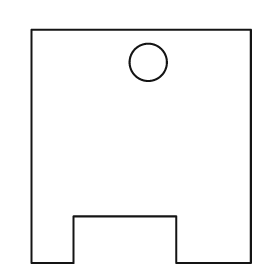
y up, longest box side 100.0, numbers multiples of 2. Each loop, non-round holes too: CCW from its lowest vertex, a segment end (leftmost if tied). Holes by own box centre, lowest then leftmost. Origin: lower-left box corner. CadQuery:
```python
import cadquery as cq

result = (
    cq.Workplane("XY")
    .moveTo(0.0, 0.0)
    .lineTo(18.0, 0.0)
    .lineTo(18.0, 20.0)
    .lineTo(62.0, 20.0)
    .lineTo(62.0, 0.0)
    .lineTo(94.0, 0.0)
    .lineTo(94.0, 100.0)
    .lineTo(0.0, 100.0)
    .close()
    .moveTo(50.0, 86.0)
    .circle(8.0)
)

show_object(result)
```